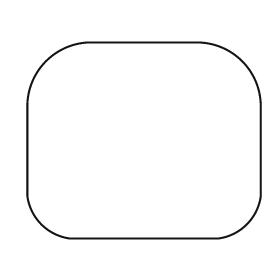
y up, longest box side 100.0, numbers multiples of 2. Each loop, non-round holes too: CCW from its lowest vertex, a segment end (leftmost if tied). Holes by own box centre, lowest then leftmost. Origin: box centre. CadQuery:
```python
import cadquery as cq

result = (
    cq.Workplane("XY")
    .moveTo(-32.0, -42.0)
    .lineTo(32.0, -42.0)
    .threePointArc((44.0, -36.0), (50.0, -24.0))
    .lineTo(50.0, 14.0)
    .threePointArc((42.0, 34.0), (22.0, 42.0))
    .lineTo(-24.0, 42.0)
    .threePointArc((-42.0, 34.0), (-50.0, 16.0))
    .lineTo(-50.0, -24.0)
    .threePointArc((-44.0, -36.0), (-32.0, -42.0))
    .close()
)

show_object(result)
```